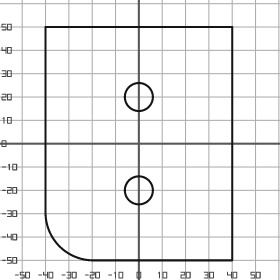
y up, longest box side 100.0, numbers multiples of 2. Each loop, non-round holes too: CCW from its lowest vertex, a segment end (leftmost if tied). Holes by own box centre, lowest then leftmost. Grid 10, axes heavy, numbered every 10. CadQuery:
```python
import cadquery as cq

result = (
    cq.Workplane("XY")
    .moveTo(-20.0, -50.0)
    .lineTo(40.0, -50.0)
    .lineTo(40.0, 50.0)
    .lineTo(-40.0, 50.0)
    .lineTo(-40.0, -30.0)
    .threePointArc((-34.0, -44.0), (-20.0, -50.0))
    .close()
    .moveTo(0.0, -20.0)
    .circle(6.0)
    .moveTo(0.0, 20.0)
    .circle(6.0)
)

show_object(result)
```